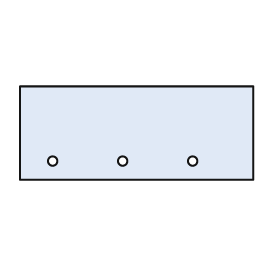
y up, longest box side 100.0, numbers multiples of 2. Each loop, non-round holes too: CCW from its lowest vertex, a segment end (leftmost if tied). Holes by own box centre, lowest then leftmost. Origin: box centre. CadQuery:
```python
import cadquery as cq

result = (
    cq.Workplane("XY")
    .moveTo(-50.0, -20.0)
    .lineTo(50.0, -20.0)
    .lineTo(50.0, 20.0)
    .lineTo(-50.0, 20.0)
    .close()
    .moveTo(-36.0, -12.0)
    .circle(2.0)
    .moveTo(-6.0, -12.0)
    .circle(2.0)
    .moveTo(24.0, -12.0)
    .circle(2.0)
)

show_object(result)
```